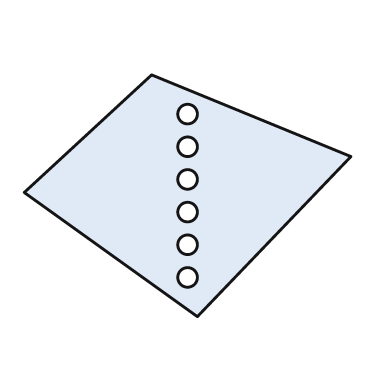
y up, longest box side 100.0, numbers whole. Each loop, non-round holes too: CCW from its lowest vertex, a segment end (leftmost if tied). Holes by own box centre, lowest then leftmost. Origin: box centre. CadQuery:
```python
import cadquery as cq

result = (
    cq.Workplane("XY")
    .moveTo(3.0, -37.0)
    .lineTo(50.0, 12.0)
    .lineTo(-11.0, 37.0)
    .lineTo(-50.0, 1.0)
    .close()
    .moveTo(0.0, -25.0)
    .circle(3.0)
    .moveTo(0.0, -15.0)
    .circle(3.0)
    .moveTo(0.0, -5.0)
    .circle(3.0)
    .moveTo(0.0, 5.0)
    .circle(3.0)
    .moveTo(0.0, 15.0)
    .circle(3.0)
    .moveTo(0.0, 25.0)
    .circle(3.0)
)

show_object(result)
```